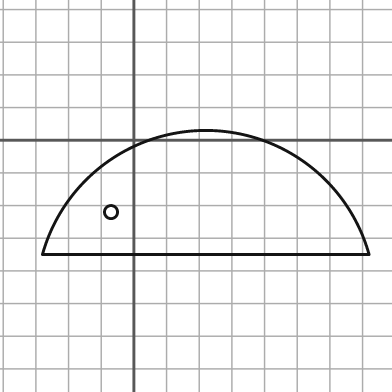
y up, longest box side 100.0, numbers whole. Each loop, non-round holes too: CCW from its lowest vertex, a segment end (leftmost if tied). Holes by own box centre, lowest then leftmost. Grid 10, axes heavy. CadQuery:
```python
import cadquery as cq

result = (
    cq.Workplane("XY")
    .moveTo(-28.0, -35.0)
    .lineTo(72.0, -35.0)
    .threePointArc((22.0, 3.0), (-28.0, -35.0))
    .close()
    .moveTo(-7.0, -22.0)
    .circle(2.0)
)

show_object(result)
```